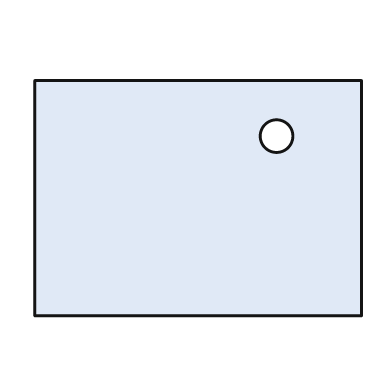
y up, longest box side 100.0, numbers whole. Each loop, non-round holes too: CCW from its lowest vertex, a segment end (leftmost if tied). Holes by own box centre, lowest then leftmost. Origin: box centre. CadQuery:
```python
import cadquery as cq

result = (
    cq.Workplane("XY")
    .moveTo(-50.0, -36.0)
    .lineTo(50.0, -36.0)
    .lineTo(50.0, 36.0)
    .lineTo(-50.0, 36.0)
    .close()
    .moveTo(24.0, 19.0)
    .circle(5.0)
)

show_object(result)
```